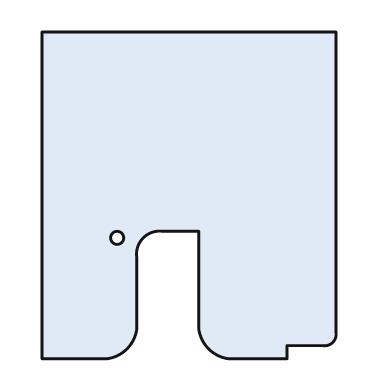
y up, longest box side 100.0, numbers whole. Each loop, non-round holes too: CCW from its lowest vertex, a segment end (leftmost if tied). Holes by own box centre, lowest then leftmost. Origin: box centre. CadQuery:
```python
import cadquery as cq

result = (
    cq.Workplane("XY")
    .moveTo(-45.0, -50.0)
    .lineTo(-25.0, -50.0)
    .threePointArc((-19.0, -47.0), (-16.0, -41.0))
    .lineTo(-16.0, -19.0)
    .threePointArc((-14.0, -13.0), (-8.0, -11.0))
    .lineTo(3.0, -11.0)
    .lineTo(3.0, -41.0)
    .threePointArc((6.0, -47.0), (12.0, -50.0))
    .lineTo(30.0, -50.0)
    .lineTo(30.0, -46.0)
    .lineTo(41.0, -46.0)
    .threePointArc((44.0, -45.0), (45.0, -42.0))
    .lineTo(45.0, 50.0)
    .lineTo(-45.0, 50.0)
    .close()
    .moveTo(-22.0, -13.0)
    .circle(2.0)
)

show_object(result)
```